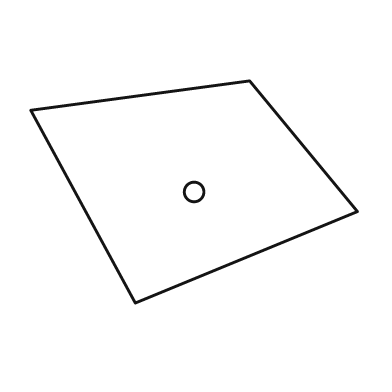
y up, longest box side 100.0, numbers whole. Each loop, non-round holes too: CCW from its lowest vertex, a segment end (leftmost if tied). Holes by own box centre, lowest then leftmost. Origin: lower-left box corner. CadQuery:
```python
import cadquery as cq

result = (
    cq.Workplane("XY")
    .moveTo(32.0, 0.0)
    .lineTo(100.0, 28.0)
    .lineTo(67.0, 68.0)
    .lineTo(0.0, 59.0)
    .close()
    .moveTo(50.0, 34.0)
    .circle(3.0)
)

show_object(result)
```